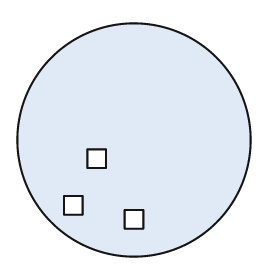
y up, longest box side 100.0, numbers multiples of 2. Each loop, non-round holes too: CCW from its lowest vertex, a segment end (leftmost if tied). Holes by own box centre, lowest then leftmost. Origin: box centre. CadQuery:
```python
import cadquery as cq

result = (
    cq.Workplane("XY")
    .moveTo(0.0, 0.0)
    .circle(50.0)
    .moveTo(-4.0, -38.0)
    .lineTo(4.0, -38.0)
    .lineTo(4.0, -30.0)
    .lineTo(-4.0, -30.0)
    .close()
    .moveTo(-30.0, -32.0)
    .lineTo(-22.0, -32.0)
    .lineTo(-22.0, -24.0)
    .lineTo(-30.0, -24.0)
    .close()
    .moveTo(-20.0, -12.0)
    .lineTo(-12.0, -12.0)
    .lineTo(-12.0, -4.0)
    .lineTo(-20.0, -4.0)
    .close()
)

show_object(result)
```